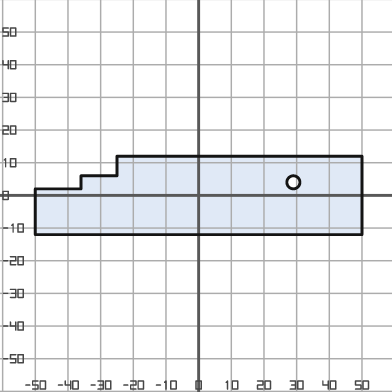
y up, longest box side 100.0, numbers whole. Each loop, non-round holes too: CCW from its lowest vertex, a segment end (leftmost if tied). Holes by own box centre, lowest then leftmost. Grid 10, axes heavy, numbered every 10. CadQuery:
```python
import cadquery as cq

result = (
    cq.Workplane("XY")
    .moveTo(-50.0, -12.0)
    .lineTo(50.0, -12.0)
    .lineTo(50.0, 12.0)
    .lineTo(-25.0, 12.0)
    .lineTo(-25.0, 6.0)
    .lineTo(-36.0, 6.0)
    .lineTo(-36.0, 2.0)
    .lineTo(-50.0, 2.0)
    .close()
    .moveTo(29.0, 4.0)
    .circle(2.0)
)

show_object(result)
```